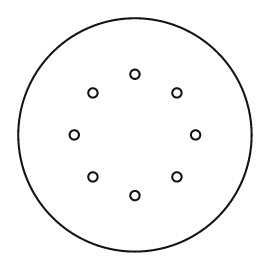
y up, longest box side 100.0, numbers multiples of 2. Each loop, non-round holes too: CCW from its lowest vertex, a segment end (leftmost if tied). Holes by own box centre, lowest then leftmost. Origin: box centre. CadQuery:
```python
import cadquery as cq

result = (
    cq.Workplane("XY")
    .moveTo(0.0, 0.0)
    .circle(50.0)
    .moveTo(0.0, -26.0)
    .circle(2.0)
    .moveTo(-18.0, -18.0)
    .circle(2.0)
    .moveTo(18.0, -18.0)
    .circle(2.0)
    .moveTo(-26.0, 0.0)
    .circle(2.0)
    .moveTo(26.0, 0.0)
    .circle(2.0)
    .moveTo(-18.0, 18.0)
    .circle(2.0)
    .moveTo(18.0, 18.0)
    .circle(2.0)
    .moveTo(0.0, 26.0)
    .circle(2.0)
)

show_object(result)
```